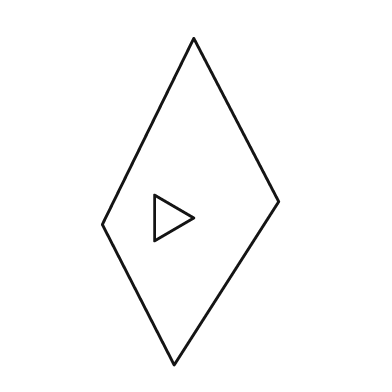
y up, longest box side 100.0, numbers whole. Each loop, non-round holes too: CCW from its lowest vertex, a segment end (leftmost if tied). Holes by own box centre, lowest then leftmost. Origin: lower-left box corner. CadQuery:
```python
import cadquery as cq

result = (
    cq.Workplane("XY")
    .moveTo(22.0, 0.0)
    .lineTo(54.0, 50.0)
    .lineTo(28.0, 100.0)
    .lineTo(0.0, 43.0)
    .close()
    .moveTo(16.0, 38.0)
    .lineTo(28.0, 45.0)
    .lineTo(16.0, 52.0)
    .close()
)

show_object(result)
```